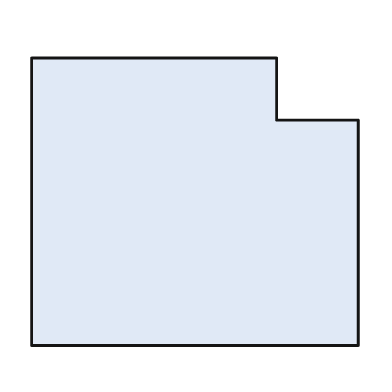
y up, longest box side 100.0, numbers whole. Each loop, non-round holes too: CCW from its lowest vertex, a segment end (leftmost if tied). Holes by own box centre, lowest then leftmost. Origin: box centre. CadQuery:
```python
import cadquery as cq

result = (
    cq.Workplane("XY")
    .moveTo(-50.0, -44.0)
    .lineTo(50.0, -44.0)
    .lineTo(50.0, 25.0)
    .lineTo(25.0, 25.0)
    .lineTo(25.0, 44.0)
    .lineTo(-50.0, 44.0)
    .close()
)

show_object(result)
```